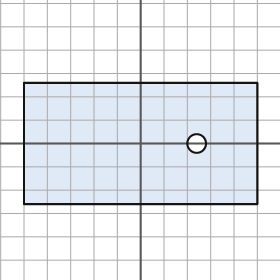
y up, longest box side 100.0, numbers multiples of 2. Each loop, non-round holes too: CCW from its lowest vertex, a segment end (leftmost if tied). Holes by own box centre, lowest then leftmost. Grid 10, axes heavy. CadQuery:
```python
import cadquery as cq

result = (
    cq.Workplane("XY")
    .moveTo(-50.0, -26.0)
    .lineTo(50.0, -26.0)
    .lineTo(50.0, 26.0)
    .lineTo(-50.0, 26.0)
    .close()
    .moveTo(24.0, 0.0)
    .circle(4.0)
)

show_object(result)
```